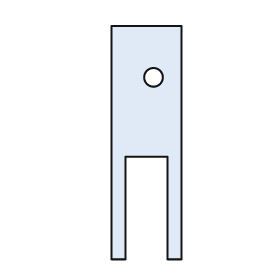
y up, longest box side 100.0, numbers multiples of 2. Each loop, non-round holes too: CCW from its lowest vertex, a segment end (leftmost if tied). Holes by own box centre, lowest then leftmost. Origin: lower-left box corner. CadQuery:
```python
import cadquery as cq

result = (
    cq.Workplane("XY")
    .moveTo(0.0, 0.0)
    .lineTo(6.0, 0.0)
    .lineTo(6.0, 44.0)
    .lineTo(24.0, 44.0)
    .lineTo(24.0, 0.0)
    .lineTo(30.0, 0.0)
    .lineTo(30.0, 100.0)
    .lineTo(0.0, 100.0)
    .close()
    .moveTo(18.0, 78.0)
    .circle(4.0)
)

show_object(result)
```